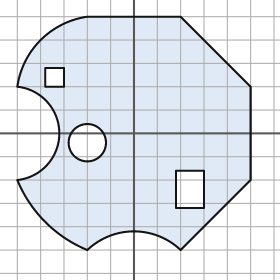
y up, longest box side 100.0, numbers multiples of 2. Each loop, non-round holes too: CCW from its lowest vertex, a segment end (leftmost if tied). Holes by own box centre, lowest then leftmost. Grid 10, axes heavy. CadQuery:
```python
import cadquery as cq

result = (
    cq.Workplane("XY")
    .moveTo(-20.0, -50.0)
    .threePointArc((0.0, -42.0), (20.0, -50.0))
    .lineTo(50.0, -20.0)
    .lineTo(50.0, 20.0)
    .lineTo(20.0, 50.0)
    .lineTo(-20.0, 50.0)
    .threePointArc((-40.0, 40.0), (-50.0, 20.0))
    .threePointArc((-32.0, 0.0), (-50.0, -20.0))
    .threePointArc((-38.0, -38.0), (-20.0, -50.0))
    .close()
    .moveTo(18.0, -32.0)
    .lineTo(30.0, -32.0)
    .lineTo(30.0, -16.0)
    .lineTo(18.0, -16.0)
    .close()
    .moveTo(-20.0, -4.0)
    .circle(8.0)
    .moveTo(-38.0, 20.0)
    .lineTo(-30.0, 20.0)
    .lineTo(-30.0, 28.0)
    .lineTo(-38.0, 28.0)
    .close()
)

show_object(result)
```